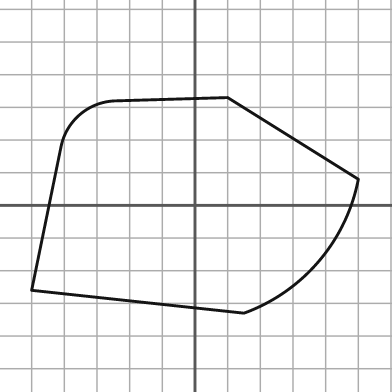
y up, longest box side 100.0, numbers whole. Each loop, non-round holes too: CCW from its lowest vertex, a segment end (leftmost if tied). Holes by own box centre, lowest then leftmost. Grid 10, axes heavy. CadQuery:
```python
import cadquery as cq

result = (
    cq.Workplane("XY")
    .moveTo(15.0, -33.0)
    .threePointArc((38.0, -17.0), (50.0, 8.0))
    .lineTo(10.0, 33.0)
    .lineTo(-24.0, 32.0)
    .threePointArc((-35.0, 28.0), (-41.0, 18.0))
    .lineTo(-50.0, -26.0)
    .close()
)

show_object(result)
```